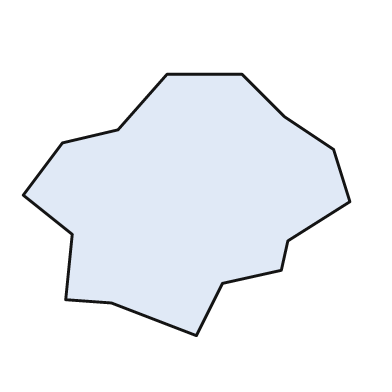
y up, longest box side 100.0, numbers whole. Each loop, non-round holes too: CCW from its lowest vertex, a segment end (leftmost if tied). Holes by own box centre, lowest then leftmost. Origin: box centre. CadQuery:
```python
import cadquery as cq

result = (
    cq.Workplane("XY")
    .moveTo(3.0, -40.0)
    .lineTo(11.0, -24.0)
    .lineTo(29.0, -20.0)
    .lineTo(31.0, -11.0)
    .lineTo(50.0, 1.0)
    .lineTo(45.0, 17.0)
    .lineTo(30.0, 27.0)
    .lineTo(17.0, 40.0)
    .lineTo(-6.0, 40.0)
    .lineTo(-21.0, 23.0)
    .lineTo(-38.0, 19.0)
    .lineTo(-50.0, 3.0)
    .lineTo(-35.0, -9.0)
    .lineTo(-37.0, -29.0)
    .lineTo(-23.0, -30.0)
    .close()
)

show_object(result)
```